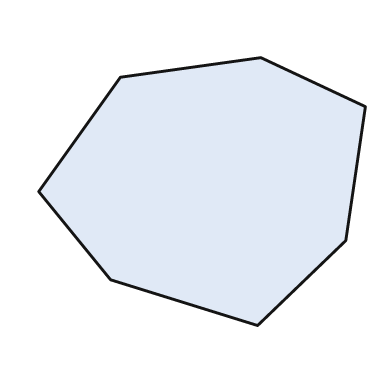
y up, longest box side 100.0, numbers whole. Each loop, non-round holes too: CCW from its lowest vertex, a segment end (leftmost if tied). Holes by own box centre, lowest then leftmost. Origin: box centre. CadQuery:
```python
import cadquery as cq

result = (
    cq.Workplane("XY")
    .moveTo(17.0, -41.0)
    .lineTo(44.0, -15.0)
    .lineTo(50.0, 26.0)
    .lineTo(18.0, 41.0)
    .lineTo(-25.0, 35.0)
    .lineTo(-50.0, 0.0)
    .lineTo(-28.0, -27.0)
    .close()
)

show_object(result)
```